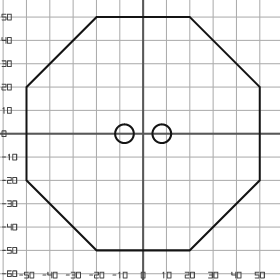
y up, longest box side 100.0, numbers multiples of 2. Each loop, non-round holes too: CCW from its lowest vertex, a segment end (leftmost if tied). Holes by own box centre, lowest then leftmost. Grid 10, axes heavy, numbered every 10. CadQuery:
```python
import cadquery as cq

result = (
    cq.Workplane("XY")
    .moveTo(-20.0, -50.0)
    .lineTo(20.0, -50.0)
    .lineTo(50.0, -20.0)
    .lineTo(50.0, 20.0)
    .lineTo(20.0, 50.0)
    .lineTo(-20.0, 50.0)
    .lineTo(-50.0, 20.0)
    .lineTo(-50.0, -20.0)
    .close()
    .moveTo(-8.0, 0.0)
    .circle(4.0)
    .moveTo(8.0, 0.0)
    .circle(4.0)
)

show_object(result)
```